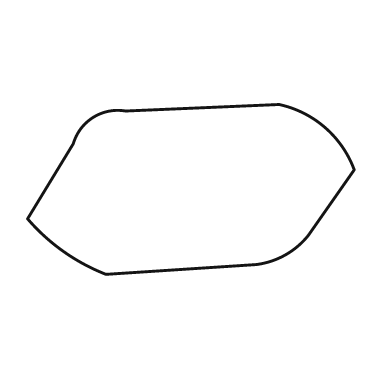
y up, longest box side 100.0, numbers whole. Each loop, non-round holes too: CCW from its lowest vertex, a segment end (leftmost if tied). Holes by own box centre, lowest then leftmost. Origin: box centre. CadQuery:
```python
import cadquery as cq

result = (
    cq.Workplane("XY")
    .moveTo(-26.0, -26.0)
    .lineTo(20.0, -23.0)
    .threePointArc((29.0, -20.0), (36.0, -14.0))
    .lineTo(50.0, 6.0)
    .threePointArc((41.0, 19.0), (27.0, 26.0))
    .lineTo(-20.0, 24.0)
    .threePointArc((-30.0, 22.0), (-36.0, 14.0))
    .lineTo(-50.0, -9.0)
    .threePointArc((-39.0, -19.0), (-26.0, -26.0))
    .close()
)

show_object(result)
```